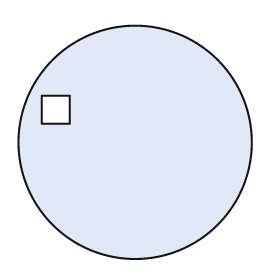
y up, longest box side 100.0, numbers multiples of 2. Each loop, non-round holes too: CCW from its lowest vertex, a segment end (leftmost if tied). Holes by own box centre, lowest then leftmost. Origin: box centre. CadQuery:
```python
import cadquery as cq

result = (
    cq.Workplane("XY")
    .moveTo(0.0, 0.0)
    .circle(50.0)
    .moveTo(-40.0, 8.0)
    .lineTo(-28.0, 8.0)
    .lineTo(-28.0, 20.0)
    .lineTo(-40.0, 20.0)
    .close()
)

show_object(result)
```